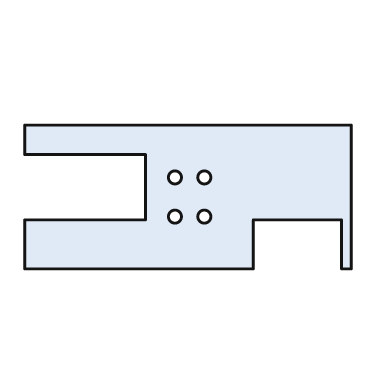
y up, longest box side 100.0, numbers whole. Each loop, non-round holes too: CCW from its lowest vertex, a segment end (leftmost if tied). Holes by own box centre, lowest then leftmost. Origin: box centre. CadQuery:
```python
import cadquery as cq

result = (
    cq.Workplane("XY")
    .moveTo(-50.0, -22.0)
    .lineTo(20.0, -22.0)
    .lineTo(20.0, -7.0)
    .lineTo(47.0, -7.0)
    .lineTo(47.0, -22.0)
    .lineTo(50.0, -22.0)
    .lineTo(50.0, 22.0)
    .lineTo(-50.0, 22.0)
    .lineTo(-50.0, 13.0)
    .lineTo(-13.0, 13.0)
    .lineTo(-13.0, -7.0)
    .lineTo(-50.0, -7.0)
    .close()
    .moveTo(-4.0, -6.0)
    .circle(2.0)
    .moveTo(5.0, -6.0)
    .circle(2.0)
    .moveTo(-4.0, 6.0)
    .circle(2.0)
    .moveTo(5.0, 6.0)
    .circle(2.0)
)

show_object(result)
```